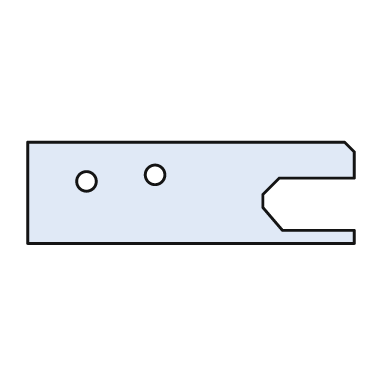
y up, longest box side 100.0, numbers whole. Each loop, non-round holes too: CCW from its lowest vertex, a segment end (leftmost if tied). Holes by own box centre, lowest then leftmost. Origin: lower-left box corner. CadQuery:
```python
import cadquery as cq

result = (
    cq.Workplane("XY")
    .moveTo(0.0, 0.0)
    .lineTo(100.0, 0.0)
    .lineTo(100.0, 4.0)
    .lineTo(78.0, 4.0)
    .lineTo(72.0, 11.0)
    .lineTo(72.0, 15.0)
    .lineTo(77.0, 20.0)
    .lineTo(100.0, 20.0)
    .lineTo(100.0, 28.0)
    .lineTo(97.0, 31.0)
    .lineTo(0.0, 31.0)
    .close()
    .moveTo(18.0, 19.0)
    .circle(3.0)
    .moveTo(39.0, 21.0)
    .circle(3.0)
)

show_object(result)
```